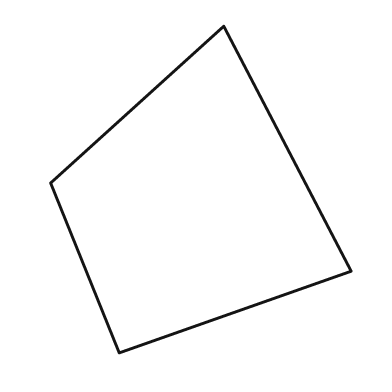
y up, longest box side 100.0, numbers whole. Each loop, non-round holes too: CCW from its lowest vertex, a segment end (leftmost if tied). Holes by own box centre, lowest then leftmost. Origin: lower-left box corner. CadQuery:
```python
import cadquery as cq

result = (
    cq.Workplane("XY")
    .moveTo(21.0, 0.0)
    .lineTo(92.0, 25.0)
    .lineTo(53.0, 100.0)
    .lineTo(0.0, 52.0)
    .close()
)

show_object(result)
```